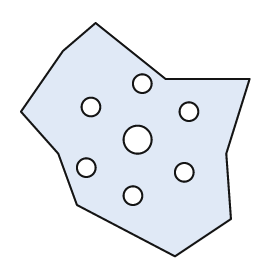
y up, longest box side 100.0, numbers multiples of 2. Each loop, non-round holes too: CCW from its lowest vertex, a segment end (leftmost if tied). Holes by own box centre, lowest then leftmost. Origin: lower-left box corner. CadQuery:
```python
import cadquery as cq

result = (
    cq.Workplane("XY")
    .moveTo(66.0, 0.0)
    .lineTo(90.0, 16.0)
    .lineTo(88.0, 44.0)
    .lineTo(98.0, 76.0)
    .lineTo(62.0, 76.0)
    .lineTo(32.0, 100.0)
    .lineTo(18.0, 88.0)
    .lineTo(0.0, 62.0)
    .lineTo(16.0, 44.0)
    .lineTo(24.0, 22.0)
    .close()
    .moveTo(48.0, 26.0)
    .circle(4.0)
    .moveTo(70.0, 36.0)
    .circle(4.0)
    .moveTo(28.0, 38.0)
    .circle(4.0)
    .moveTo(50.0, 50.0)
    .circle(6.0)
    .moveTo(72.0, 62.0)
    .circle(4.0)
    .moveTo(30.0, 64.0)
    .circle(4.0)
    .moveTo(52.0, 74.0)
    .circle(4.0)
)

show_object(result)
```